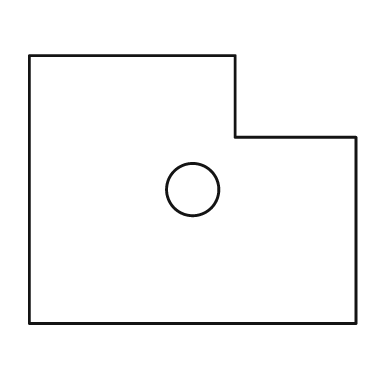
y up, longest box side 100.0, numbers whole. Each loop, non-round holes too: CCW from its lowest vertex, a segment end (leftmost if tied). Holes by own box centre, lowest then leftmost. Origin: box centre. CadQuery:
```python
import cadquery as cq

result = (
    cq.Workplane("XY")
    .moveTo(-50.0, -41.0)
    .lineTo(50.0, -41.0)
    .lineTo(50.0, 16.0)
    .lineTo(13.0, 16.0)
    .lineTo(13.0, 41.0)
    .lineTo(-50.0, 41.0)
    .close()
    .moveTo(0.0, 0.0)
    .circle(8.0)
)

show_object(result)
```